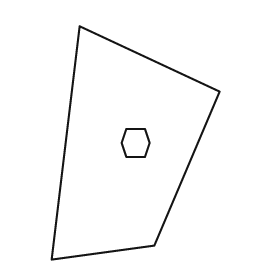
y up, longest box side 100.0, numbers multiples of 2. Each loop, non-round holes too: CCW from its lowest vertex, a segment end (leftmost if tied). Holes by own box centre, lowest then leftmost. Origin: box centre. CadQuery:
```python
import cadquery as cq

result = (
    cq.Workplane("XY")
    .moveTo(-36.0, -50.0)
    .lineTo(8.0, -44.0)
    .lineTo(36.0, 22.0)
    .lineTo(-24.0, 50.0)
    .close()
    .moveTo(-4.0, -6.0)
    .lineTo(4.0, -6.0)
    .lineTo(6.0, 0.0)
    .lineTo(4.0, 6.0)
    .lineTo(-4.0, 6.0)
    .lineTo(-6.0, 0.0)
    .close()
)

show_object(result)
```